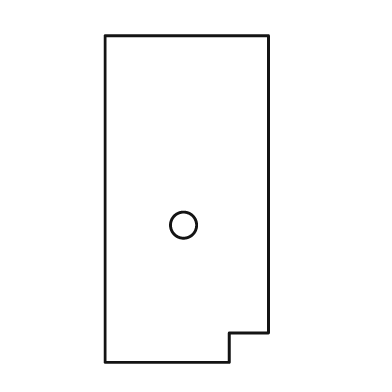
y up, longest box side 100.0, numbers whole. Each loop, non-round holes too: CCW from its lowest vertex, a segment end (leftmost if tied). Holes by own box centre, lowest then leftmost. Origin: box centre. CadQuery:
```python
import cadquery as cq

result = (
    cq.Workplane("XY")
    .moveTo(-25.0, -50.0)
    .lineTo(13.0, -50.0)
    .lineTo(13.0, -41.0)
    .lineTo(25.0, -41.0)
    .lineTo(25.0, 50.0)
    .lineTo(-25.0, 50.0)
    .close()
    .moveTo(-1.0, -8.0)
    .circle(4.0)
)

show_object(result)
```